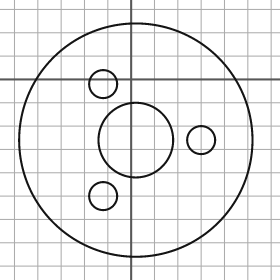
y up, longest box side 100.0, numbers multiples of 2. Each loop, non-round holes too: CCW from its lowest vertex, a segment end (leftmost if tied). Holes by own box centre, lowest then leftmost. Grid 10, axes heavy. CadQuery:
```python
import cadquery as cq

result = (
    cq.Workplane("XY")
    .moveTo(2.0, -26.0)
    .circle(50.0)
    .moveTo(-12.0, -50.0)
    .circle(6.0)
    .moveTo(2.0, -26.0)
    .circle(16.0)
    .moveTo(30.0, -26.0)
    .circle(6.0)
    .moveTo(-12.0, -2.0)
    .circle(6.0)
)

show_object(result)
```